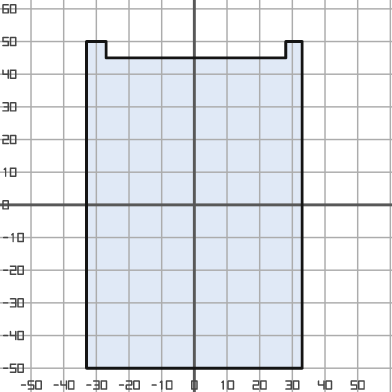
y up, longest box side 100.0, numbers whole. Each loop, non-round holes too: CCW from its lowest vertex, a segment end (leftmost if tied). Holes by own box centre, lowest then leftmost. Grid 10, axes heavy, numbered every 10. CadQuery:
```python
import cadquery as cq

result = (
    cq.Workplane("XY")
    .moveTo(-33.0, -50.0)
    .lineTo(33.0, -50.0)
    .lineTo(33.0, 50.0)
    .lineTo(28.0, 50.0)
    .lineTo(28.0, 45.0)
    .lineTo(-27.0, 45.0)
    .lineTo(-27.0, 50.0)
    .lineTo(-33.0, 50.0)
    .close()
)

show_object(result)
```